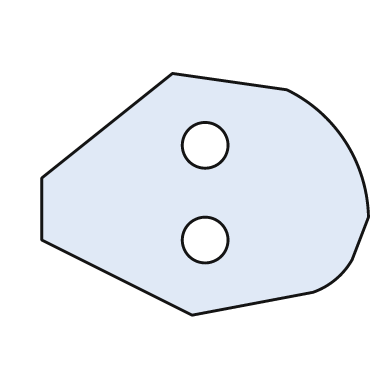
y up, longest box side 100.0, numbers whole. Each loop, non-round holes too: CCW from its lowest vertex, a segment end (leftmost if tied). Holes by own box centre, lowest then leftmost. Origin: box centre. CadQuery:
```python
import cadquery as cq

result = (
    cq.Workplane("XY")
    .moveTo(-4.0, -37.0)
    .lineTo(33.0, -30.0)
    .threePointArc((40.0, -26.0), (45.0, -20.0))
    .lineTo(50.0, -7.0)
    .threePointArc((43.0, 16.0), (25.0, 32.0))
    .lineTo(-10.0, 37.0)
    .lineTo(-50.0, 5.0)
    .lineTo(-50.0, -14.0)
    .close()
    .moveTo(0.0, -14.0)
    .circle(7.0)
    .moveTo(0.0, 15.0)
    .circle(7.0)
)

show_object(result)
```